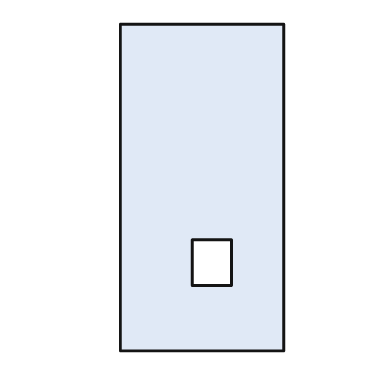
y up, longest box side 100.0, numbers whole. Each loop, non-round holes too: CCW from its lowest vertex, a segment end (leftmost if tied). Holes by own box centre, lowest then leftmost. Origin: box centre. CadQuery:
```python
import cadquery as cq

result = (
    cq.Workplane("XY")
    .moveTo(-25.0, -50.0)
    .lineTo(25.0, -50.0)
    .lineTo(25.0, 50.0)
    .lineTo(-25.0, 50.0)
    .close()
    .moveTo(-3.0, -30.0)
    .lineTo(9.0, -30.0)
    .lineTo(9.0, -16.0)
    .lineTo(-3.0, -16.0)
    .close()
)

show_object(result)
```